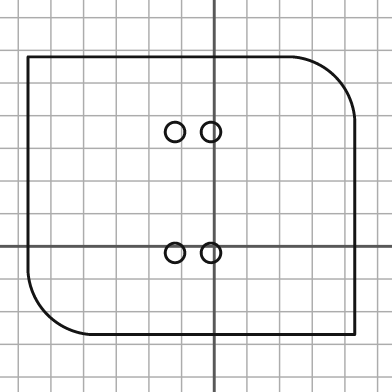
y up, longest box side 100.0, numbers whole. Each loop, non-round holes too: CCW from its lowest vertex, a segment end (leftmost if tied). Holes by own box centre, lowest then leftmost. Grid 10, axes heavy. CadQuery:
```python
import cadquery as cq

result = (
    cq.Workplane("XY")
    .moveTo(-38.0, -27.0)
    .lineTo(43.0, -27.0)
    .lineTo(43.0, 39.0)
    .threePointArc((37.0, 52.0), (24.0, 58.0))
    .lineTo(-57.0, 58.0)
    .lineTo(-57.0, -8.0)
    .threePointArc((-51.0, -21.0), (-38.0, -27.0))
    .close()
    .moveTo(-12.0, -2.0)
    .circle(3.0)
    .moveTo(-1.0, -2.0)
    .circle(3.0)
    .moveTo(-12.0, 35.0)
    .circle(3.0)
    .moveTo(-1.0, 35.0)
    .circle(3.0)
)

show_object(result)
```